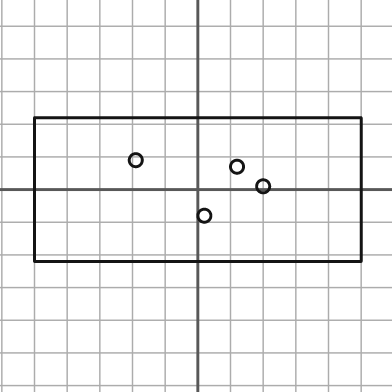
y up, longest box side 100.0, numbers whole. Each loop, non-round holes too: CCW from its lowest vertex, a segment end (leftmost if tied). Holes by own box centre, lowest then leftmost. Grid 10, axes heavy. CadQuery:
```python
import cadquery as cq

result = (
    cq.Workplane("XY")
    .moveTo(-50.0, -22.0)
    .lineTo(50.0, -22.0)
    .lineTo(50.0, 22.0)
    .lineTo(-50.0, 22.0)
    .close()
    .moveTo(2.0, -8.0)
    .circle(2.0)
    .moveTo(20.0, 1.0)
    .circle(2.0)
    .moveTo(12.0, 7.0)
    .circle(2.0)
    .moveTo(-19.0, 9.0)
    .circle(2.0)
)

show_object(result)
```